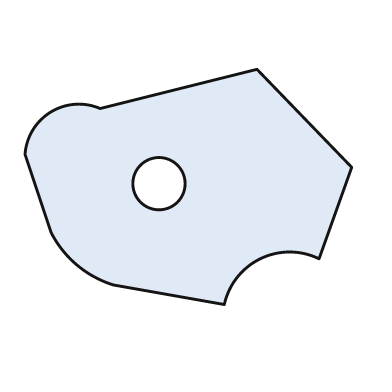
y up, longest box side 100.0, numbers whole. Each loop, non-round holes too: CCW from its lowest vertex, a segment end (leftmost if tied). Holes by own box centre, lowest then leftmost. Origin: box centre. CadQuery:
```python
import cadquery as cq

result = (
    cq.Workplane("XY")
    .moveTo(11.0, -36.0)
    .threePointArc((22.0, -22.0), (40.0, -22.0))
    .lineTo(50.0, 6.0)
    .lineTo(21.0, 36.0)
    .lineTo(-27.0, 24.0)
    .threePointArc((-42.0, 23.0), (-50.0, 10.0))
    .lineTo(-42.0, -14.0)
    .threePointArc((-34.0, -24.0), (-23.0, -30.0))
    .close()
    .moveTo(-9.0, 1.0)
    .circle(8.0)
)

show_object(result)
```